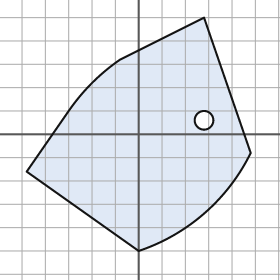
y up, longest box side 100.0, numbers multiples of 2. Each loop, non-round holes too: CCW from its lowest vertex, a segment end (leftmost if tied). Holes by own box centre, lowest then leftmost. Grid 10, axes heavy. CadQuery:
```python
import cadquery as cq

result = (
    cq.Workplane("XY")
    .moveTo(0.0, -50.0)
    .threePointArc((28.0, -34.0), (48.0, -8.0))
    .lineTo(28.0, 50.0)
    .lineTo(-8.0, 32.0)
    .threePointArc((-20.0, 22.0), (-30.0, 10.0))
    .lineTo(-48.0, -16.0)
    .close()
    .moveTo(28.0, 6.0)
    .circle(4.0)
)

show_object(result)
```